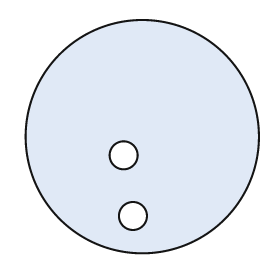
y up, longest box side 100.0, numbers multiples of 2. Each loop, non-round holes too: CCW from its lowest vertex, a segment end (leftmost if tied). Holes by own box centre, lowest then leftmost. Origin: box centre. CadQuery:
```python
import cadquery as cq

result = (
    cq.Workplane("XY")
    .moveTo(0.0, 0.0)
    .circle(50.0)
    .moveTo(-4.0, -34.0)
    .circle(6.0)
    .moveTo(-8.0, -8.0)
    .circle(6.0)
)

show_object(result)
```